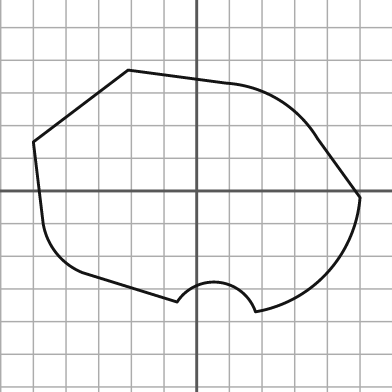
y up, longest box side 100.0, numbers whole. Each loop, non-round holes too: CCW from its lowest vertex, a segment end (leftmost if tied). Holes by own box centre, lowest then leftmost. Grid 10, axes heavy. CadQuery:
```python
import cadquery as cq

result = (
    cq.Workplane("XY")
    .moveTo(18.0, -37.0)
    .threePointArc((40.0, -25.0), (50.0, -2.0))
    .lineTo(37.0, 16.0)
    .threePointArc((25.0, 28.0), (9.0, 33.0))
    .lineTo(-21.0, 37.0)
    .lineTo(-50.0, 15.0)
    .lineTo(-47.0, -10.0)
    .threePointArc((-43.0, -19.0), (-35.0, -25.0))
    .lineTo(-6.0, -34.0)
    .threePointArc((7.0, -28.0), (18.0, -37.0))
    .close()
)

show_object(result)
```